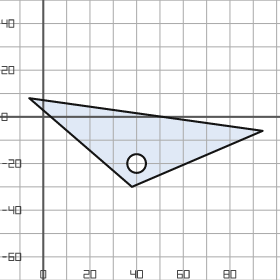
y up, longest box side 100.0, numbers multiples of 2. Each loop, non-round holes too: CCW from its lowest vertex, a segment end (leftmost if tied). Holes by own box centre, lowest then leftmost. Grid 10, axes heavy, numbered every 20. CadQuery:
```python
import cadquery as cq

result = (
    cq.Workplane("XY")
    .moveTo(38.0, -30.0)
    .lineTo(94.0, -6.0)
    .lineTo(-6.0, 8.0)
    .close()
    .moveTo(40.0, -20.0)
    .circle(4.0)
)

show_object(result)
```